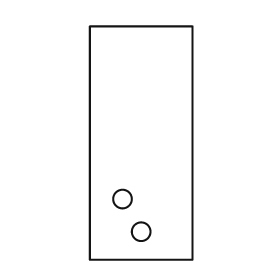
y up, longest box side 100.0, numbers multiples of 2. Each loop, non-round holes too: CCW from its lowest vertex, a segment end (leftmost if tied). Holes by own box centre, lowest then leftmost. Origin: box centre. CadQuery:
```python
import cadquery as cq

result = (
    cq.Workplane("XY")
    .moveTo(-22.0, -50.0)
    .lineTo(22.0, -50.0)
    .lineTo(22.0, 50.0)
    .lineTo(-22.0, 50.0)
    .close()
    .moveTo(0.0, -38.0)
    .circle(4.0)
    .moveTo(-8.0, -24.0)
    .circle(4.0)
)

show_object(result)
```